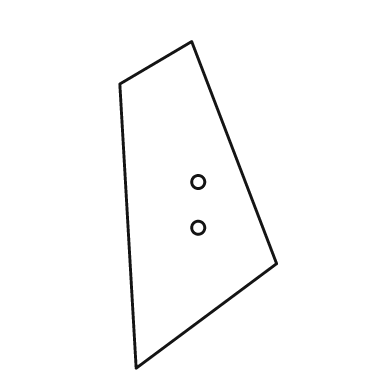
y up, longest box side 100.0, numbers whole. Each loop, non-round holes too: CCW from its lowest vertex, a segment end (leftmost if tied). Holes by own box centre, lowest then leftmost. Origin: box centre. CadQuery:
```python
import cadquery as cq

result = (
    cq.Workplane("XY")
    .moveTo(-19.0, -50.0)
    .lineTo(24.0, -18.0)
    .lineTo(-2.0, 50.0)
    .lineTo(-24.0, 37.0)
    .close()
    .moveTo(0.0, -7.0)
    .circle(2.0)
    .moveTo(0.0, 7.0)
    .circle(2.0)
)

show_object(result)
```